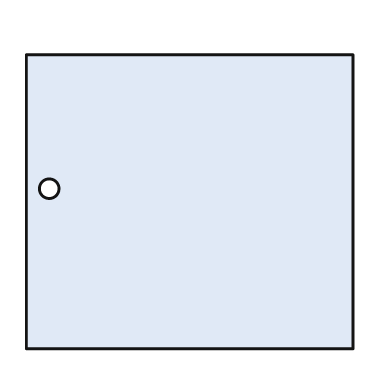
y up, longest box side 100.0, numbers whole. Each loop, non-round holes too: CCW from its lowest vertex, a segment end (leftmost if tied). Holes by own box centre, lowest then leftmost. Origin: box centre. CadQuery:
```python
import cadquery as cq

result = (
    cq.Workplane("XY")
    .moveTo(-50.0, -45.0)
    .lineTo(50.0, -45.0)
    .lineTo(50.0, 45.0)
    .lineTo(-50.0, 45.0)
    .close()
    .moveTo(-43.0, 4.0)
    .circle(3.0)
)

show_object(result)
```